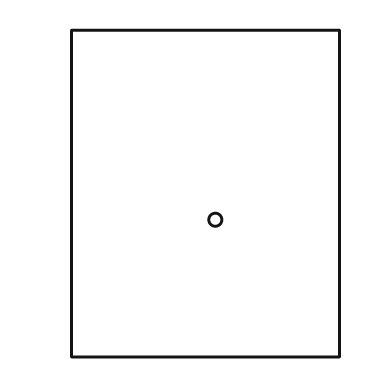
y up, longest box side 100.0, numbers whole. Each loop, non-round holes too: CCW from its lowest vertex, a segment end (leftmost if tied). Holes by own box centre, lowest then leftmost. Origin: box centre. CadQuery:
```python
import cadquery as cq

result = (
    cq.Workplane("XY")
    .moveTo(-41.0, -50.0)
    .lineTo(41.0, -50.0)
    .lineTo(41.0, 50.0)
    .lineTo(-41.0, 50.0)
    .close()
    .moveTo(3.0, -8.0)
    .circle(2.0)
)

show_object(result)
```